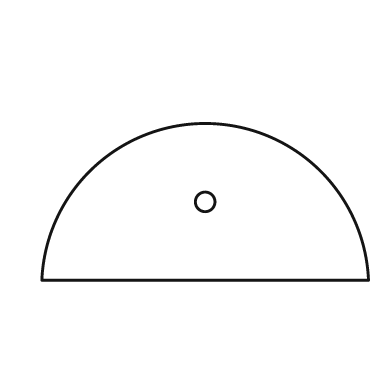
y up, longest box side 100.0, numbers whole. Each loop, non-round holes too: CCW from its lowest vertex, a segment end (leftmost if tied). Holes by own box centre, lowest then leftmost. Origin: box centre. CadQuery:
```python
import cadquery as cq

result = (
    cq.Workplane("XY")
    .moveTo(-50.0, -24.0)
    .lineTo(50.0, -24.0)
    .threePointArc((0.0, 24.0), (-50.0, -24.0))
    .close()
    .moveTo(0.0, 0.0)
    .circle(3.0)
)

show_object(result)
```